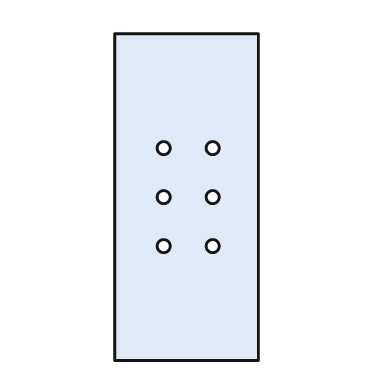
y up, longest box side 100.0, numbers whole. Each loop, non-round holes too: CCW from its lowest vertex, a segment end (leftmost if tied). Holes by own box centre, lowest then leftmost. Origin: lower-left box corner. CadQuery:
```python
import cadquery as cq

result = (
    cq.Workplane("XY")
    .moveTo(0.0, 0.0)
    .lineTo(44.0, 0.0)
    .lineTo(44.0, 100.0)
    .lineTo(0.0, 100.0)
    .close()
    .moveTo(15.0, 35.0)
    .circle(2.0)
    .moveTo(30.0, 35.0)
    .circle(2.0)
    .moveTo(15.0, 50.0)
    .circle(2.0)
    .moveTo(30.0, 50.0)
    .circle(2.0)
    .moveTo(15.0, 65.0)
    .circle(2.0)
    .moveTo(30.0, 65.0)
    .circle(2.0)
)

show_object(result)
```